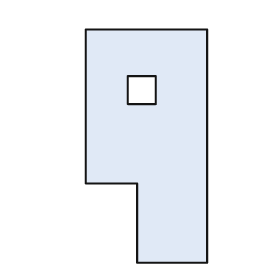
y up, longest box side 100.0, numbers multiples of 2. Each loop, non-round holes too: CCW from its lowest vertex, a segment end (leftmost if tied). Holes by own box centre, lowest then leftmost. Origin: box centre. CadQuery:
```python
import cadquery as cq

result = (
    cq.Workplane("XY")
    .moveTo(-4.0, -50.0)
    .lineTo(26.0, -50.0)
    .lineTo(26.0, 50.0)
    .lineTo(-26.0, 50.0)
    .lineTo(-26.0, -16.0)
    .lineTo(-4.0, -16.0)
    .close()
    .moveTo(-8.0, 18.0)
    .lineTo(4.0, 18.0)
    .lineTo(4.0, 30.0)
    .lineTo(-8.0, 30.0)
    .close()
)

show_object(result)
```